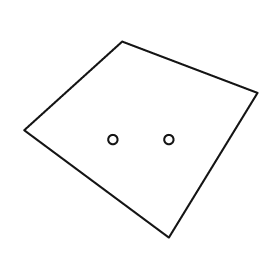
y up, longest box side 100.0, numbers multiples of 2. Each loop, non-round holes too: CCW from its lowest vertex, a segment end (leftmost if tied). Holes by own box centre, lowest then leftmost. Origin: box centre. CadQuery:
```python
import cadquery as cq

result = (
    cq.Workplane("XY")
    .moveTo(12.0, -42.0)
    .lineTo(50.0, 20.0)
    .lineTo(-8.0, 42.0)
    .lineTo(-50.0, 4.0)
    .close()
    .moveTo(-12.0, 0.0)
    .circle(2.0)
    .moveTo(12.0, 0.0)
    .circle(2.0)
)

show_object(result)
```